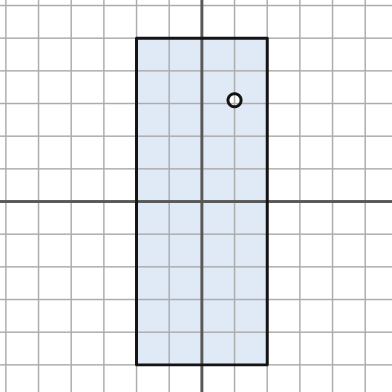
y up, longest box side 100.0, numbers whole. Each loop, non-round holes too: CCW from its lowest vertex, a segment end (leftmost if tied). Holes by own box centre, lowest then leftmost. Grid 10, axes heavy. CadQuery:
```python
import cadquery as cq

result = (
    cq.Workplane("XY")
    .moveTo(-20.0, -50.0)
    .lineTo(20.0, -50.0)
    .lineTo(20.0, 50.0)
    .lineTo(-20.0, 50.0)
    .close()
    .moveTo(10.0, 31.0)
    .circle(2.0)
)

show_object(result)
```